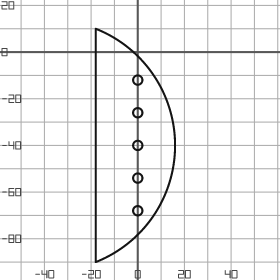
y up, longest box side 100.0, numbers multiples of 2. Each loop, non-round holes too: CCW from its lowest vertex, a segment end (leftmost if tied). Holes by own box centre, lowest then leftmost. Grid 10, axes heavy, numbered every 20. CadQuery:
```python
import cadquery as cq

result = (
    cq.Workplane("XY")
    .moveTo(-18.0, -90.0)
    .threePointArc((16.0, -40.0), (-18.0, 10.0))
    .close()
    .moveTo(0.0, -68.0)
    .circle(2.0)
    .moveTo(0.0, -54.0)
    .circle(2.0)
    .moveTo(0.0, -40.0)
    .circle(2.0)
    .moveTo(0.0, -26.0)
    .circle(2.0)
    .moveTo(0.0, -12.0)
    .circle(2.0)
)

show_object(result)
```